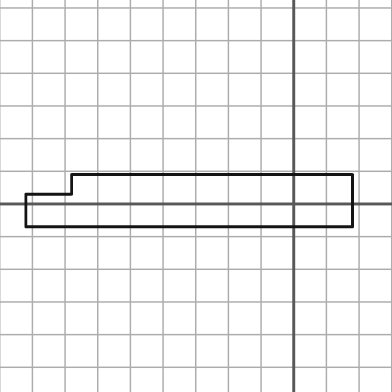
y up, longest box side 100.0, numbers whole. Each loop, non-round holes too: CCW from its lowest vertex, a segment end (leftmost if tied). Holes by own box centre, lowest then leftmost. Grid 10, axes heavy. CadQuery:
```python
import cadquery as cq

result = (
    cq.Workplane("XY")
    .moveTo(-82.0, -7.0)
    .lineTo(18.0, -7.0)
    .lineTo(18.0, 9.0)
    .lineTo(-68.0, 9.0)
    .lineTo(-68.0, 3.0)
    .lineTo(-82.0, 3.0)
    .close()
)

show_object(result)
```